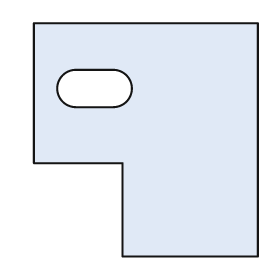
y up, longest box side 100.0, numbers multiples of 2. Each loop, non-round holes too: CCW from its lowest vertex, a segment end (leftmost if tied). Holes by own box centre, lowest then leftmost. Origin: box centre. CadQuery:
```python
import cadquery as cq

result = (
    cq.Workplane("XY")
    .moveTo(-10.0, -50.0)
    .lineTo(48.0, -50.0)
    .lineTo(48.0, 50.0)
    .lineTo(-48.0, 50.0)
    .lineTo(-48.0, -10.0)
    .lineTo(-10.0, -10.0)
    .close()
    .moveTo(-30.0, 14.0)
    .lineTo(-14.0, 14.0)
    .threePointArc((-6.0, 22.0), (-14.0, 30.0))
    .lineTo(-30.0, 30.0)
    .threePointArc((-38.0, 22.0), (-30.0, 14.0))
    .close()
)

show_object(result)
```